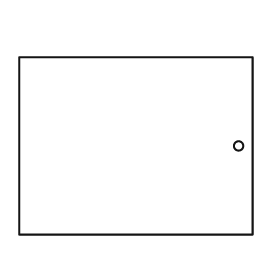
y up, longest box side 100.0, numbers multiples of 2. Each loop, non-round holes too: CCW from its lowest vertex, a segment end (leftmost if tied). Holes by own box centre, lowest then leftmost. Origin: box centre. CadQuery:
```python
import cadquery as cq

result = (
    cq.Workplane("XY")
    .moveTo(-50.0, -38.0)
    .lineTo(50.0, -38.0)
    .lineTo(50.0, 38.0)
    .lineTo(-50.0, 38.0)
    .close()
    .moveTo(44.0, 0.0)
    .circle(2.0)
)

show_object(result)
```